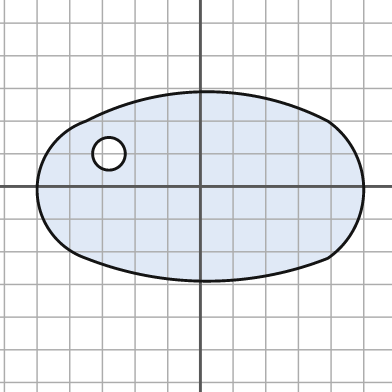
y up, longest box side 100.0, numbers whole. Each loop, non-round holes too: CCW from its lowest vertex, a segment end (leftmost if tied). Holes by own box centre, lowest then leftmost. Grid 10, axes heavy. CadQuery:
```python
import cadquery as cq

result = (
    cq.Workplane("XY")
    .moveTo(-35.0, -22.0)
    .threePointArc((2.0, -29.0), (39.0, -22.0))
    .threePointArc((50.0, -1.0), (39.0, 20.0))
    .threePointArc((2.0, 29.0), (-35.0, 20.0))
    .threePointArc((-50.0, -1.0), (-35.0, -22.0))
    .close()
    .moveTo(-28.0, 10.0)
    .circle(5.0)
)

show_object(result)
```